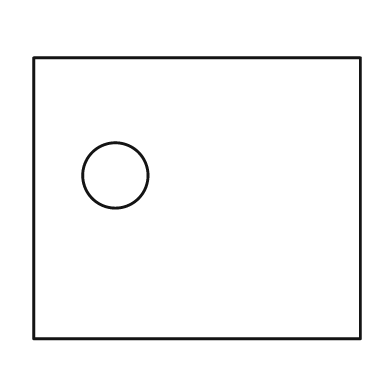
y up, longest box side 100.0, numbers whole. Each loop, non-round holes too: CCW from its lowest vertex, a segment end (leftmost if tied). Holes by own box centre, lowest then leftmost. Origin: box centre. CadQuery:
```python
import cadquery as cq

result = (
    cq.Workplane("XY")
    .moveTo(-50.0, -43.0)
    .lineTo(50.0, -43.0)
    .lineTo(50.0, 43.0)
    .lineTo(-50.0, 43.0)
    .close()
    .moveTo(-25.0, 7.0)
    .circle(10.0)
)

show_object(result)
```